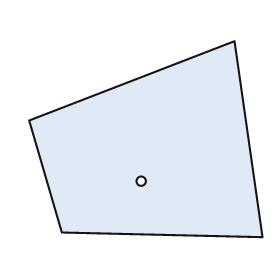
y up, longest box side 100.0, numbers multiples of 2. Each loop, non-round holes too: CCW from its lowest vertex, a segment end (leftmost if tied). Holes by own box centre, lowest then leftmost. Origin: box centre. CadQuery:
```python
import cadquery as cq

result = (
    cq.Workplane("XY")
    .moveTo(50.0, -42.0)
    .lineTo(38.0, 42.0)
    .lineTo(-50.0, 8.0)
    .lineTo(-36.0, -40.0)
    .close()
    .moveTo(-2.0, -18.0)
    .circle(2.0)
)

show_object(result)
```